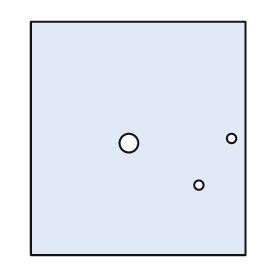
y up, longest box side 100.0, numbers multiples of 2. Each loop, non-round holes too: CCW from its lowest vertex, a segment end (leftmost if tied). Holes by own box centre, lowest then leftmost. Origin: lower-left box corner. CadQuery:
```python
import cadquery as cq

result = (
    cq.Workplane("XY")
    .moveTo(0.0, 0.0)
    .lineTo(92.0, 0.0)
    .lineTo(92.0, 100.0)
    .lineTo(0.0, 100.0)
    .close()
    .moveTo(72.0, 30.0)
    .circle(2.0)
    .moveTo(42.0, 48.0)
    .circle(4.0)
    .moveTo(86.0, 50.0)
    .circle(2.0)
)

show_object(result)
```